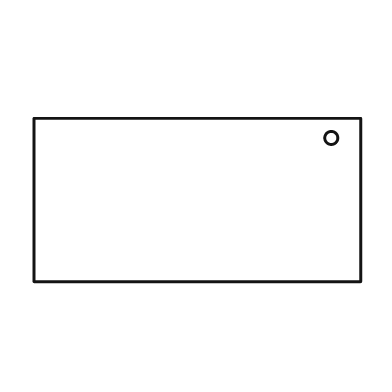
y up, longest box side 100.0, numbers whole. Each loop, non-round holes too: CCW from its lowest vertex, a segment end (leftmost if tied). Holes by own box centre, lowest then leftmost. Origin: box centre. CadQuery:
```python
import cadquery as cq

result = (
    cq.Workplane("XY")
    .moveTo(-50.0, -25.0)
    .lineTo(50.0, -25.0)
    .lineTo(50.0, 25.0)
    .lineTo(-50.0, 25.0)
    .close()
    .moveTo(41.0, 19.0)
    .circle(2.0)
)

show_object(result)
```